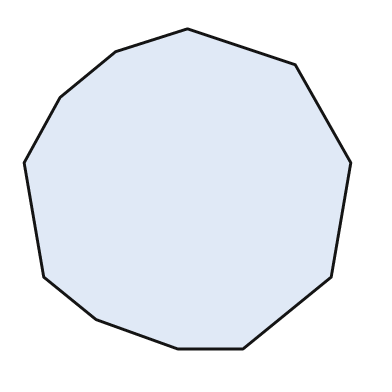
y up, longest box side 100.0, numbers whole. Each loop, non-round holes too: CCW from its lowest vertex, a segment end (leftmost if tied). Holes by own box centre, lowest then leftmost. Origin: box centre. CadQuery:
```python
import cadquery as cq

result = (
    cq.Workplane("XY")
    .moveTo(-3.0, -49.0)
    .lineTo(17.0, -49.0)
    .lineTo(44.0, -27.0)
    .lineTo(50.0, 8.0)
    .lineTo(33.0, 38.0)
    .lineTo(0.0, 49.0)
    .lineTo(-22.0, 42.0)
    .lineTo(-39.0, 28.0)
    .lineTo(-50.0, 8.0)
    .lineTo(-44.0, -27.0)
    .lineTo(-28.0, -40.0)
    .close()
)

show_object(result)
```